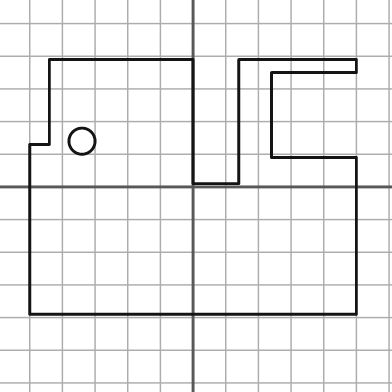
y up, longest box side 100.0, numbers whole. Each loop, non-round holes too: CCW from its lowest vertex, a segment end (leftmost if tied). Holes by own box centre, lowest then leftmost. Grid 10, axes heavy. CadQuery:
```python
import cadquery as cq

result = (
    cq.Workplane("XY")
    .moveTo(-50.0, -39.0)
    .lineTo(50.0, -39.0)
    .lineTo(50.0, 9.0)
    .lineTo(24.0, 9.0)
    .lineTo(24.0, 35.0)
    .lineTo(50.0, 35.0)
    .lineTo(50.0, 39.0)
    .lineTo(14.0, 39.0)
    .lineTo(14.0, 1.0)
    .lineTo(0.0, 1.0)
    .lineTo(0.0, 39.0)
    .lineTo(-44.0, 39.0)
    .lineTo(-44.0, 13.0)
    .lineTo(-50.0, 13.0)
    .close()
    .moveTo(-34.0, 14.0)
    .circle(4.0)
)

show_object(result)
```